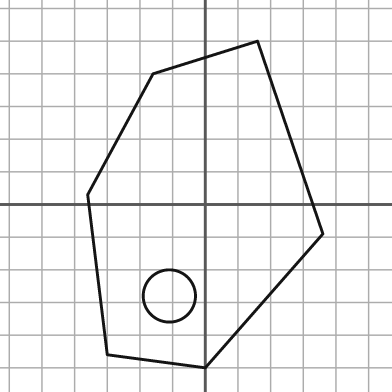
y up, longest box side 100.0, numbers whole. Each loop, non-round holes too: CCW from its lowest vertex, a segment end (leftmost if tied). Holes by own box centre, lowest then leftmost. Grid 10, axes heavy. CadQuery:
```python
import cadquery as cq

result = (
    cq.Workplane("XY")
    .moveTo(0.0, -50.0)
    .lineTo(36.0, -9.0)
    .lineTo(16.0, 50.0)
    .lineTo(-16.0, 40.0)
    .lineTo(-36.0, 3.0)
    .lineTo(-30.0, -46.0)
    .close()
    .moveTo(-11.0, -28.0)
    .circle(8.0)
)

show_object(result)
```